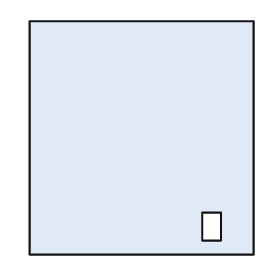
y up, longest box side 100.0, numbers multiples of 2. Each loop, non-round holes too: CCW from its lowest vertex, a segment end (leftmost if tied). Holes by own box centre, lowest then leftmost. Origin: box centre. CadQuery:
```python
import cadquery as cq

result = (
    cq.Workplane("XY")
    .moveTo(-48.0, -50.0)
    .lineTo(48.0, -50.0)
    .lineTo(48.0, 50.0)
    .lineTo(-48.0, 50.0)
    .close()
    .moveTo(26.0, -44.0)
    .lineTo(34.0, -44.0)
    .lineTo(34.0, -32.0)
    .lineTo(26.0, -32.0)
    .close()
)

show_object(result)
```